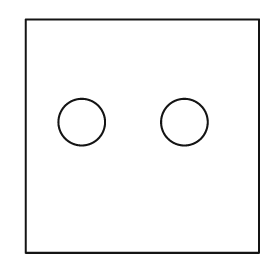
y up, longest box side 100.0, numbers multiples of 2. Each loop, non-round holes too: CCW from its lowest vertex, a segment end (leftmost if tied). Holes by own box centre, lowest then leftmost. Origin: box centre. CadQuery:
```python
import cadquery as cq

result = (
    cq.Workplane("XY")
    .moveTo(-50.0, -50.0)
    .lineTo(50.0, -50.0)
    .lineTo(50.0, 50.0)
    .lineTo(-50.0, 50.0)
    .close()
    .moveTo(-26.0, 6.0)
    .circle(10.0)
    .moveTo(18.0, 6.0)
    .circle(10.0)
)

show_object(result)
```